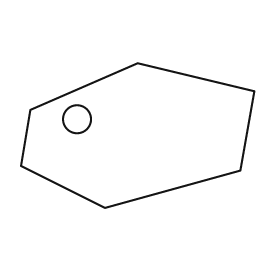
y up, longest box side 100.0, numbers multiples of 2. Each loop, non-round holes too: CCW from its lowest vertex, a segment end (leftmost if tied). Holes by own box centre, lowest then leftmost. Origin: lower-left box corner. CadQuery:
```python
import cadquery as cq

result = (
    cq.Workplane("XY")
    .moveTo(36.0, 0.0)
    .lineTo(94.0, 16.0)
    .lineTo(100.0, 50.0)
    .lineTo(50.0, 62.0)
    .lineTo(4.0, 42.0)
    .lineTo(0.0, 18.0)
    .close()
    .moveTo(24.0, 38.0)
    .circle(6.0)
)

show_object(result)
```